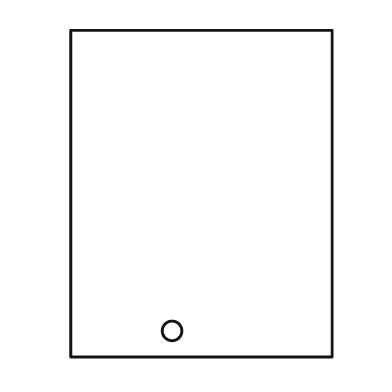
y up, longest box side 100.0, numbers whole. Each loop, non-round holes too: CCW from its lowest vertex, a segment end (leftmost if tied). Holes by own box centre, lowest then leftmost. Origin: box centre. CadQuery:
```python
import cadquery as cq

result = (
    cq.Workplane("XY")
    .moveTo(-40.0, -50.0)
    .lineTo(40.0, -50.0)
    .lineTo(40.0, 50.0)
    .lineTo(-40.0, 50.0)
    .close()
    .moveTo(-9.0, -42.0)
    .circle(3.0)
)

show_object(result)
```